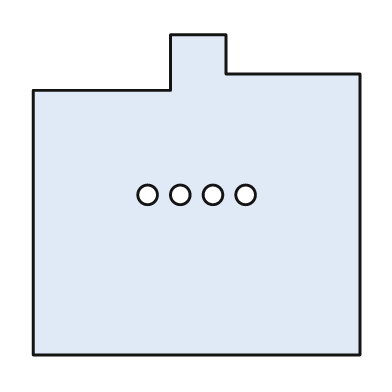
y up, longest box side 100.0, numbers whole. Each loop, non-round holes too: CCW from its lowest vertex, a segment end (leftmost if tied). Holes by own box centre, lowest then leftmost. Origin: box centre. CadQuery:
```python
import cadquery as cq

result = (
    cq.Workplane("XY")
    .moveTo(-50.0, -49.0)
    .lineTo(50.0, -49.0)
    .lineTo(50.0, 37.0)
    .lineTo(9.0, 37.0)
    .lineTo(9.0, 49.0)
    .lineTo(-8.0, 49.0)
    .lineTo(-8.0, 32.0)
    .lineTo(-50.0, 32.0)
    .close()
    .moveTo(-15.0, 0.0)
    .circle(3.0)
    .moveTo(-5.0, 0.0)
    .circle(3.0)
    .moveTo(5.0, 0.0)
    .circle(3.0)
    .moveTo(15.0, 0.0)
    .circle(3.0)
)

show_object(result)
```